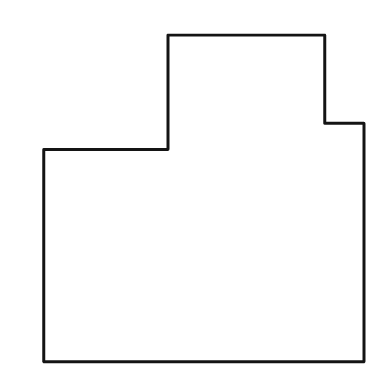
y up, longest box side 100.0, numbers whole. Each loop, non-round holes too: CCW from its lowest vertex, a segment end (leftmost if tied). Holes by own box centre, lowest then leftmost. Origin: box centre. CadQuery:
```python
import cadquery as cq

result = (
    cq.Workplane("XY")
    .moveTo(-49.0, -50.0)
    .lineTo(49.0, -50.0)
    .lineTo(49.0, 23.0)
    .lineTo(37.0, 23.0)
    .lineTo(37.0, 50.0)
    .lineTo(-11.0, 50.0)
    .lineTo(-11.0, 15.0)
    .lineTo(-49.0, 15.0)
    .close()
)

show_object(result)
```